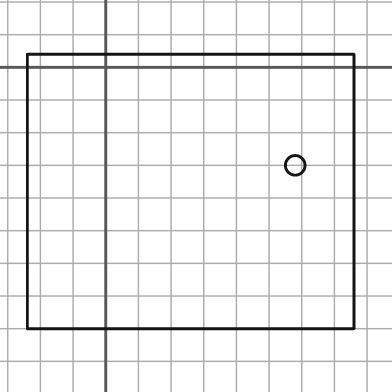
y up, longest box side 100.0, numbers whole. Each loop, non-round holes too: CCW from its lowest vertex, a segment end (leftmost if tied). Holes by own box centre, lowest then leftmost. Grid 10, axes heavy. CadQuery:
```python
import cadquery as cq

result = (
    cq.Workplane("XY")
    .moveTo(-24.0, -80.0)
    .lineTo(76.0, -80.0)
    .lineTo(76.0, 4.0)
    .lineTo(-24.0, 4.0)
    .close()
    .moveTo(58.0, -30.0)
    .circle(3.0)
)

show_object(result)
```